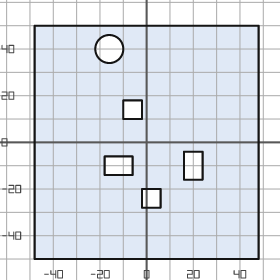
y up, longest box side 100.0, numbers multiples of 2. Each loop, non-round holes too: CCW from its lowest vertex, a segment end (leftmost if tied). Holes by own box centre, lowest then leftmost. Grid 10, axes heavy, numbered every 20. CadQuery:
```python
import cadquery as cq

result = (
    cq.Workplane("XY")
    .moveTo(-48.0, -50.0)
    .lineTo(48.0, -50.0)
    .lineTo(48.0, 50.0)
    .lineTo(-48.0, 50.0)
    .close()
    .moveTo(-2.0, -28.0)
    .lineTo(6.0, -28.0)
    .lineTo(6.0, -20.0)
    .lineTo(-2.0, -20.0)
    .close()
    .moveTo(-18.0, -14.0)
    .lineTo(-6.0, -14.0)
    .lineTo(-6.0, -6.0)
    .lineTo(-18.0, -6.0)
    .close()
    .moveTo(16.0, -16.0)
    .lineTo(24.0, -16.0)
    .lineTo(24.0, -4.0)
    .lineTo(16.0, -4.0)
    .close()
    .moveTo(-10.0, 10.0)
    .lineTo(-2.0, 10.0)
    .lineTo(-2.0, 18.0)
    .lineTo(-10.0, 18.0)
    .close()
    .moveTo(-16.0, 40.0)
    .circle(6.0)
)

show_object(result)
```